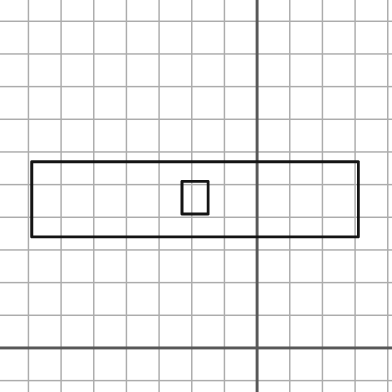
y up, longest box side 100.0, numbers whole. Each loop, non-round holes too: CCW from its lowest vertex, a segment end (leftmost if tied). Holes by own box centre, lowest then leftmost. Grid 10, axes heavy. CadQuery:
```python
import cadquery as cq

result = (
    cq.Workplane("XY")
    .moveTo(-69.0, 34.0)
    .lineTo(31.0, 34.0)
    .lineTo(31.0, 57.0)
    .lineTo(-69.0, 57.0)
    .close()
    .moveTo(-23.0, 41.0)
    .lineTo(-15.0, 41.0)
    .lineTo(-15.0, 51.0)
    .lineTo(-23.0, 51.0)
    .close()
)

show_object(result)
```